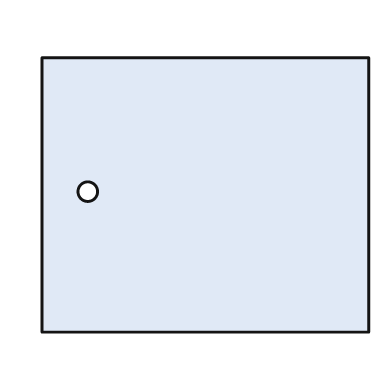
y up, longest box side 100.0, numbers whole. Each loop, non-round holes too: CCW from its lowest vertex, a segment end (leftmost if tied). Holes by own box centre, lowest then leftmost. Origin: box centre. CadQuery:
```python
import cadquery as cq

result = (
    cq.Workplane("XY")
    .moveTo(-50.0, -42.0)
    .lineTo(50.0, -42.0)
    .lineTo(50.0, 42.0)
    .lineTo(-50.0, 42.0)
    .close()
    .moveTo(-36.0, 1.0)
    .circle(3.0)
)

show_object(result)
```